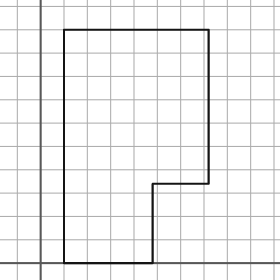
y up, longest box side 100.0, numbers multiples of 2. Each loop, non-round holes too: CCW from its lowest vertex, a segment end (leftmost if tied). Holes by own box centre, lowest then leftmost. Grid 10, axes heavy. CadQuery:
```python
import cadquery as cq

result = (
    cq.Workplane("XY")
    .moveTo(10.0, 0.0)
    .lineTo(48.0, 0.0)
    .lineTo(48.0, 34.0)
    .lineTo(72.0, 34.0)
    .lineTo(72.0, 100.0)
    .lineTo(10.0, 100.0)
    .close()
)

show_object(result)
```